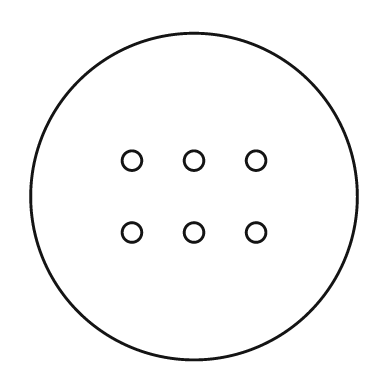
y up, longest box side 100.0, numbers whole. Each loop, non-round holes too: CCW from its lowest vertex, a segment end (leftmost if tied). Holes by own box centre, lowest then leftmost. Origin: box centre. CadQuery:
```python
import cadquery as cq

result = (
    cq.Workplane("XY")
    .moveTo(0.0, 0.0)
    .circle(50.0)
    .moveTo(-19.0, -11.0)
    .circle(3.0)
    .moveTo(0.0, -11.0)
    .circle(3.0)
    .moveTo(19.0, -11.0)
    .circle(3.0)
    .moveTo(-19.0, 11.0)
    .circle(3.0)
    .moveTo(0.0, 11.0)
    .circle(3.0)
    .moveTo(19.0, 11.0)
    .circle(3.0)
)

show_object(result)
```